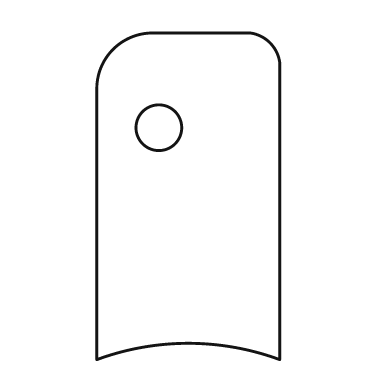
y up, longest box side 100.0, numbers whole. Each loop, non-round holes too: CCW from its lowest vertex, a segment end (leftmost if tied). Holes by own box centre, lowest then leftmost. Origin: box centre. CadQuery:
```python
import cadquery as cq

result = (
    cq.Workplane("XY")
    .moveTo(-28.0, -50.0)
    .threePointArc((0.0, -45.0), (28.0, -50.0))
    .lineTo(28.0, 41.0)
    .threePointArc((25.0, 47.0), (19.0, 50.0))
    .lineTo(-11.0, 50.0)
    .threePointArc((-23.0, 45.0), (-28.0, 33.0))
    .close()
    .moveTo(-9.0, 21.0)
    .circle(7.0)
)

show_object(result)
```